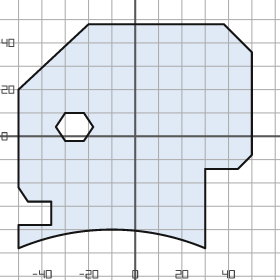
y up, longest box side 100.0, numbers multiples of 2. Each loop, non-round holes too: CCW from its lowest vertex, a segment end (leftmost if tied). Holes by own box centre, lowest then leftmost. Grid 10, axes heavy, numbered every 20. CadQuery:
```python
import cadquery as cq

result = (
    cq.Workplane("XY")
    .moveTo(-50.0, -48.0)
    .threePointArc((-10.0, -40.0), (30.0, -48.0))
    .lineTo(30.0, -14.0)
    .lineTo(44.0, -14.0)
    .lineTo(50.0, -8.0)
    .lineTo(50.0, 36.0)
    .lineTo(38.0, 48.0)
    .lineTo(-20.0, 48.0)
    .lineTo(-50.0, 20.0)
    .lineTo(-50.0, -22.0)
    .lineTo(-46.0, -28.0)
    .lineTo(-36.0, -28.0)
    .lineTo(-36.0, -38.0)
    .lineTo(-50.0, -38.0)
    .close()
    .moveTo(-30.0, -2.0)
    .lineTo(-22.0, -2.0)
    .lineTo(-18.0, 4.0)
    .lineTo(-22.0, 10.0)
    .lineTo(-30.0, 10.0)
    .lineTo(-34.0, 4.0)
    .close()
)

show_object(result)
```